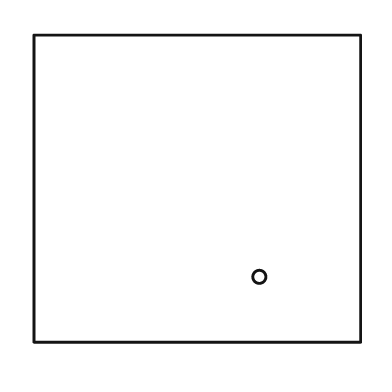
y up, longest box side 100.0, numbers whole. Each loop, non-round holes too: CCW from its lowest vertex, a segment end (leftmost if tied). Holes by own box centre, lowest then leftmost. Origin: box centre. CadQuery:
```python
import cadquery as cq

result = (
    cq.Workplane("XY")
    .moveTo(-50.0, -47.0)
    .lineTo(50.0, -47.0)
    .lineTo(50.0, 47.0)
    .lineTo(-50.0, 47.0)
    .close()
    .moveTo(19.0, -27.0)
    .circle(2.0)
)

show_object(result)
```